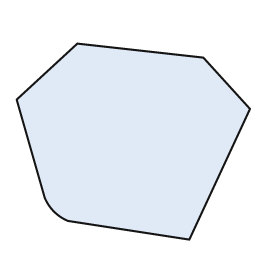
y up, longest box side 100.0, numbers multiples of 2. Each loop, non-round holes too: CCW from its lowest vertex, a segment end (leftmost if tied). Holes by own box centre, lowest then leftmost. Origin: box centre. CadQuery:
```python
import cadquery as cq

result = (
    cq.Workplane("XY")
    .moveTo(24.0, -42.0)
    .lineTo(50.0, 14.0)
    .lineTo(30.0, 36.0)
    .lineTo(-24.0, 42.0)
    .lineTo(-50.0, 18.0)
    .lineTo(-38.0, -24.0)
    .threePointArc((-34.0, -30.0), (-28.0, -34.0))
    .close()
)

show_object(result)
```